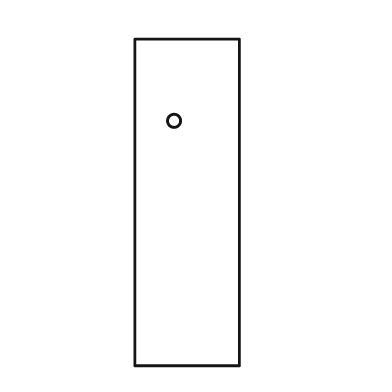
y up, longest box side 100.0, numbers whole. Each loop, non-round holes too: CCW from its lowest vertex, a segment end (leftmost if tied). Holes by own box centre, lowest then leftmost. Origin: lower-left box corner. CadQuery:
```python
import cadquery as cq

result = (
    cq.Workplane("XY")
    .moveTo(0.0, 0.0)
    .lineTo(32.0, 0.0)
    .lineTo(32.0, 100.0)
    .lineTo(0.0, 100.0)
    .close()
    .moveTo(12.0, 75.0)
    .circle(2.0)
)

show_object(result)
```